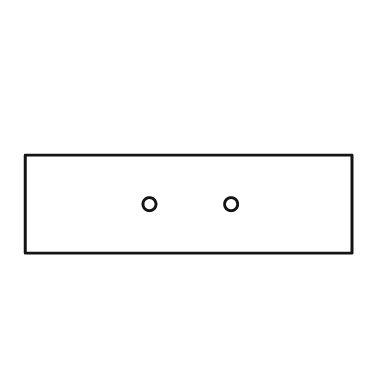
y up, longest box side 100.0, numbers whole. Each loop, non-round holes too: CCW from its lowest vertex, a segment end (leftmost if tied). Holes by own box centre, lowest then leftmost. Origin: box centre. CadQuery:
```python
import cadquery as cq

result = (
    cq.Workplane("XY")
    .moveTo(-50.0, -15.0)
    .lineTo(50.0, -15.0)
    .lineTo(50.0, 15.0)
    .lineTo(-50.0, 15.0)
    .close()
    .moveTo(-12.0, 0.0)
    .circle(2.0)
    .moveTo(13.0, 0.0)
    .circle(2.0)
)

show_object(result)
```